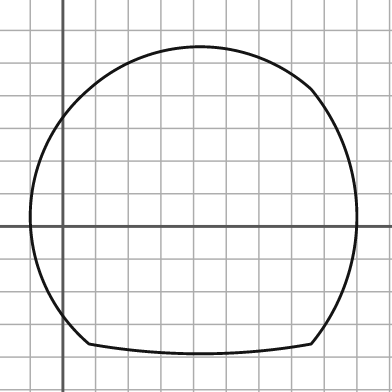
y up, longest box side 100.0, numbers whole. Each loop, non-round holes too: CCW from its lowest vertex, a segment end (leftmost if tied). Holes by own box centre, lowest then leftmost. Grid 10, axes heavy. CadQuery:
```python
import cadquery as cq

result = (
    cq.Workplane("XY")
    .moveTo(8.0, -36.0)
    .threePointArc((42.0, -39.0), (76.0, -36.0))
    .threePointArc((90.0, 3.0), (76.0, 42.0))
    .threePointArc((42.0, 55.0), (8.0, 42.0))
    .threePointArc((-10.0, 3.0), (8.0, -36.0))
    .close()
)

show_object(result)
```